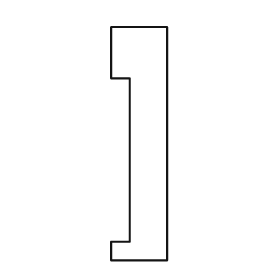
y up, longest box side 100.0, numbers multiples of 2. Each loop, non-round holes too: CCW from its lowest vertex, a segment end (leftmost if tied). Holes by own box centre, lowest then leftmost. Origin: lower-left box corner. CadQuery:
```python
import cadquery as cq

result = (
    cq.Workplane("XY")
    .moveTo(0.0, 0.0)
    .lineTo(24.0, 0.0)
    .lineTo(24.0, 100.0)
    .lineTo(0.0, 100.0)
    .lineTo(0.0, 78.0)
    .lineTo(8.0, 78.0)
    .lineTo(8.0, 8.0)
    .lineTo(0.0, 8.0)
    .close()
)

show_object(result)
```